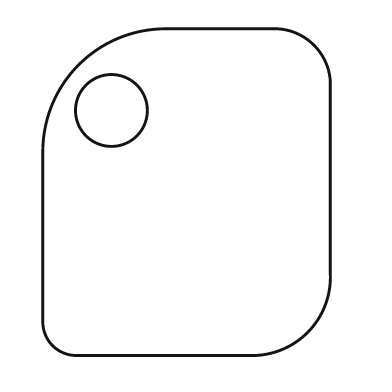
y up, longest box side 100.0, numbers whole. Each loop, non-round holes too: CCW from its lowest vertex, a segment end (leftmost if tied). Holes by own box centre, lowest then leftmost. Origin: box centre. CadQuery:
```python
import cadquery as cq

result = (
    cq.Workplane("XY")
    .moveTo(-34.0, -50.0)
    .lineTo(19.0, -50.0)
    .threePointArc((37.0, -43.0), (44.0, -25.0))
    .lineTo(44.0, 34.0)
    .threePointArc((39.0, 45.0), (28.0, 50.0))
    .lineTo(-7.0, 50.0)
    .threePointArc((-33.0, 39.0), (-44.0, 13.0))
    .lineTo(-44.0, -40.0)
    .threePointArc((-41.0, -47.0), (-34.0, -50.0))
    .close()
    .moveTo(-23.0, 25.0)
    .circle(11.0)
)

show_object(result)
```